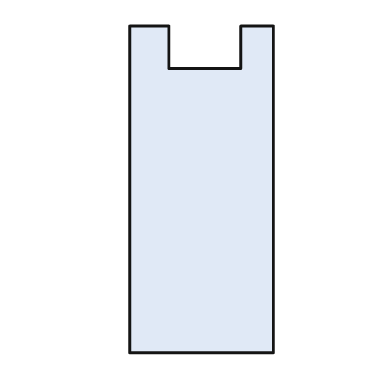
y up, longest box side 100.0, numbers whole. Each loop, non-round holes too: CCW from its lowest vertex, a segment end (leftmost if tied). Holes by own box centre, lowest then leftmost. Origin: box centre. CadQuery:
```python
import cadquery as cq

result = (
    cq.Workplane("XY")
    .moveTo(-22.0, -50.0)
    .lineTo(22.0, -50.0)
    .lineTo(22.0, 50.0)
    .lineTo(12.0, 50.0)
    .lineTo(12.0, 37.0)
    .lineTo(-10.0, 37.0)
    .lineTo(-10.0, 50.0)
    .lineTo(-22.0, 50.0)
    .close()
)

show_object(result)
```